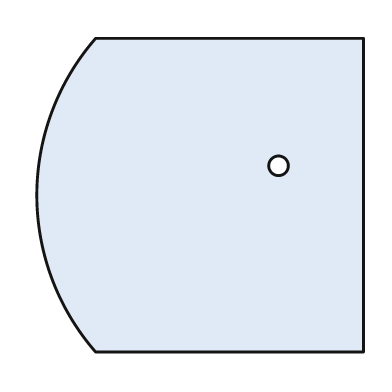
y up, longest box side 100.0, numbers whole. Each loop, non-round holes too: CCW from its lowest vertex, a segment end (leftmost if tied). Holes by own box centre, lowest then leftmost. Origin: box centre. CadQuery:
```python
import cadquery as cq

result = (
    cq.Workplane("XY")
    .moveTo(-32.0, -48.0)
    .lineTo(50.0, -48.0)
    .lineTo(50.0, 48.0)
    .lineTo(-32.0, 48.0)
    .threePointArc((-50.0, 0.0), (-32.0, -48.0))
    .close()
    .moveTo(24.0, 9.0)
    .circle(3.0)
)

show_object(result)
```